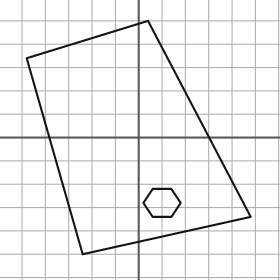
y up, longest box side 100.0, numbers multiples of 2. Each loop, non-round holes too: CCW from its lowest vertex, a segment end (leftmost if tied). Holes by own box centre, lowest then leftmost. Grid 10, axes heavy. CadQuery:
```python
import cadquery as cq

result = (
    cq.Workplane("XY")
    .moveTo(-24.0, -50.0)
    .lineTo(48.0, -34.0)
    .lineTo(4.0, 50.0)
    .lineTo(-48.0, 34.0)
    .close()
    .moveTo(6.0, -34.0)
    .lineTo(14.0, -34.0)
    .lineTo(18.0, -28.0)
    .lineTo(14.0, -22.0)
    .lineTo(6.0, -22.0)
    .lineTo(2.0, -28.0)
    .close()
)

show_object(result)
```